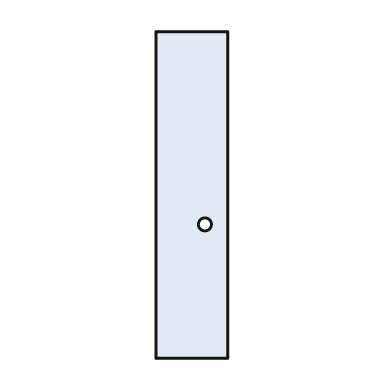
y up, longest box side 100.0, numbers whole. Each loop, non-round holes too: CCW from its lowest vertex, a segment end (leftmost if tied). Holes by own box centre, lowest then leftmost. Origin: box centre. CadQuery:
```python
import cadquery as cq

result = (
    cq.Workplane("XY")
    .moveTo(-11.0, -50.0)
    .lineTo(11.0, -50.0)
    .lineTo(11.0, 50.0)
    .lineTo(-11.0, 50.0)
    .close()
    .moveTo(4.0, -9.0)
    .circle(2.0)
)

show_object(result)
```